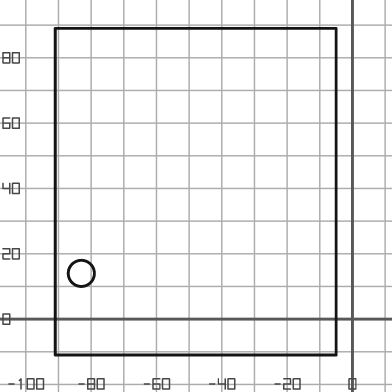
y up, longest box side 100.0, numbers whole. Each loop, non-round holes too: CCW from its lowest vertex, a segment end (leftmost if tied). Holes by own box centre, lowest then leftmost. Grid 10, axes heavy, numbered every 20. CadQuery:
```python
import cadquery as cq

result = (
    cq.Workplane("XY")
    .moveTo(-91.0, -11.0)
    .lineTo(-5.0, -11.0)
    .lineTo(-5.0, 89.0)
    .lineTo(-91.0, 89.0)
    .close()
    .moveTo(-83.0, 14.0)
    .circle(4.0)
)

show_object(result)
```